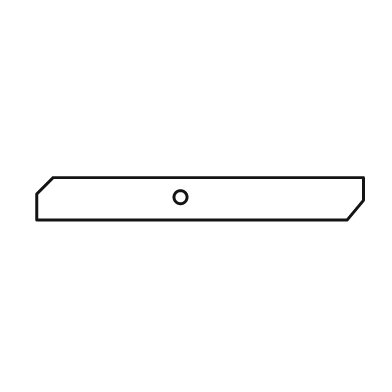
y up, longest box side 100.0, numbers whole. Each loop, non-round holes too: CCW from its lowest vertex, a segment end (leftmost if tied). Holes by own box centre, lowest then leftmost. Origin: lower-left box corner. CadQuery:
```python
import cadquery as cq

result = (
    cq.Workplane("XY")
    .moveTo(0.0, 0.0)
    .lineTo(95.0, 0.0)
    .lineTo(100.0, 6.0)
    .lineTo(100.0, 13.0)
    .lineTo(5.0, 13.0)
    .lineTo(0.0, 8.0)
    .close()
    .moveTo(44.0, 7.0)
    .circle(2.0)
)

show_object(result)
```